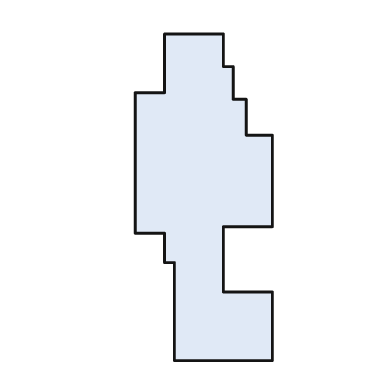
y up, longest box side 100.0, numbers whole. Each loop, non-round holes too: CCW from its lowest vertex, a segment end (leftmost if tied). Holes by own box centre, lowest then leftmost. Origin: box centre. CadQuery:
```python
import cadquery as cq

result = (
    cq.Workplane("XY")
    .moveTo(-9.0, -50.0)
    .lineTo(21.0, -50.0)
    .lineTo(21.0, -29.0)
    .lineTo(6.0, -29.0)
    .lineTo(6.0, -9.0)
    .lineTo(21.0, -9.0)
    .lineTo(21.0, 19.0)
    .lineTo(13.0, 19.0)
    .lineTo(13.0, 30.0)
    .lineTo(9.0, 30.0)
    .lineTo(9.0, 40.0)
    .lineTo(6.0, 40.0)
    .lineTo(6.0, 50.0)
    .lineTo(-12.0, 50.0)
    .lineTo(-12.0, 32.0)
    .lineTo(-21.0, 32.0)
    .lineTo(-21.0, -11.0)
    .lineTo(-12.0, -11.0)
    .lineTo(-12.0, -20.0)
    .lineTo(-9.0, -20.0)
    .close()
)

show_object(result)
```